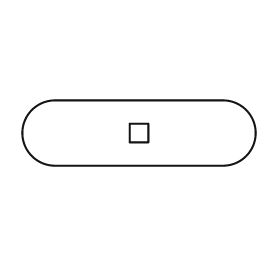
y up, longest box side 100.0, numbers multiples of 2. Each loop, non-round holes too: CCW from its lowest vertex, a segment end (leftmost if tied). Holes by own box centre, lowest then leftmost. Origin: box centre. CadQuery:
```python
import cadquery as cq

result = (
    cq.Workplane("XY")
    .moveTo(-36.0, -14.0)
    .lineTo(36.0, -14.0)
    .threePointArc((50.0, 0.0), (36.0, 14.0))
    .lineTo(-36.0, 14.0)
    .threePointArc((-50.0, 0.0), (-36.0, -14.0))
    .close()
    .moveTo(-4.0, -4.0)
    .lineTo(4.0, -4.0)
    .lineTo(4.0, 4.0)
    .lineTo(-4.0, 4.0)
    .close()
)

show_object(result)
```